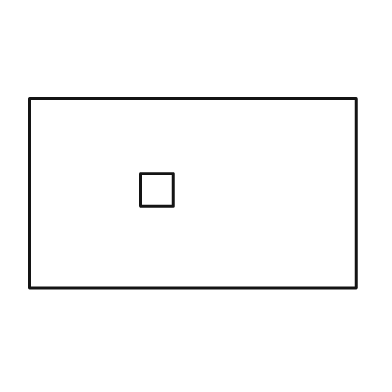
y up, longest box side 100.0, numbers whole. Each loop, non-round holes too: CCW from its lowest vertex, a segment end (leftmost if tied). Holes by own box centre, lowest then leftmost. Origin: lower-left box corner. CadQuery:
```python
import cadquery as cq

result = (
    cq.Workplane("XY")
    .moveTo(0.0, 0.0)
    .lineTo(100.0, 0.0)
    .lineTo(100.0, 58.0)
    .lineTo(0.0, 58.0)
    .close()
    .moveTo(34.0, 25.0)
    .lineTo(44.0, 25.0)
    .lineTo(44.0, 35.0)
    .lineTo(34.0, 35.0)
    .close()
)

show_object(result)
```